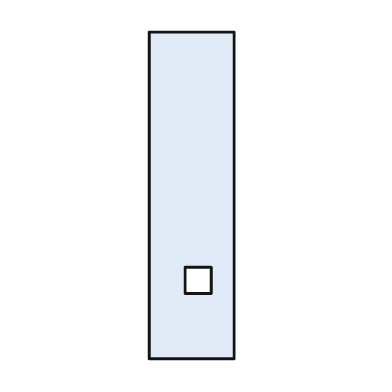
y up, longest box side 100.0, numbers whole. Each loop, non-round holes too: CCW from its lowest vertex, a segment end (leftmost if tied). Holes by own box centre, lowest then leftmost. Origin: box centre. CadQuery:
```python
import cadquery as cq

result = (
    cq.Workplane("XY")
    .moveTo(-13.0, -50.0)
    .lineTo(13.0, -50.0)
    .lineTo(13.0, 50.0)
    .lineTo(-13.0, 50.0)
    .close()
    .moveTo(-2.0, -30.0)
    .lineTo(6.0, -30.0)
    .lineTo(6.0, -22.0)
    .lineTo(-2.0, -22.0)
    .close()
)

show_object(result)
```